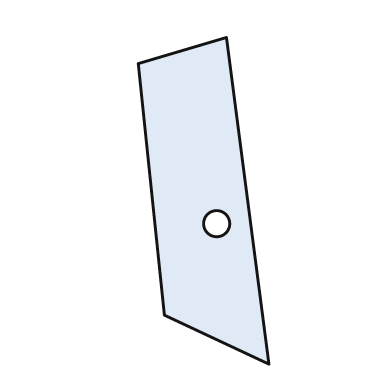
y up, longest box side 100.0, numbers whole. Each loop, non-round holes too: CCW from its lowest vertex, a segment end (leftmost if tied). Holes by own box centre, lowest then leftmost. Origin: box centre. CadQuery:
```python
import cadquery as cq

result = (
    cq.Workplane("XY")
    .moveTo(20.0, -50.0)
    .lineTo(7.0, 50.0)
    .lineTo(-20.0, 42.0)
    .lineTo(-12.0, -35.0)
    .close()
    .moveTo(4.0, -7.0)
    .circle(4.0)
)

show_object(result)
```